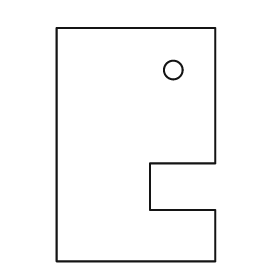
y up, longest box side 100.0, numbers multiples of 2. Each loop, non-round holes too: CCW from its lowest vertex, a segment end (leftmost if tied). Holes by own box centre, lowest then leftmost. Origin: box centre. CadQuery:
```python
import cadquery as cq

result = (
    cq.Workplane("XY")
    .moveTo(-34.0, -50.0)
    .lineTo(34.0, -50.0)
    .lineTo(34.0, -28.0)
    .lineTo(6.0, -28.0)
    .lineTo(6.0, -8.0)
    .lineTo(34.0, -8.0)
    .lineTo(34.0, 50.0)
    .lineTo(-34.0, 50.0)
    .close()
    .moveTo(16.0, 32.0)
    .circle(4.0)
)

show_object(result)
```